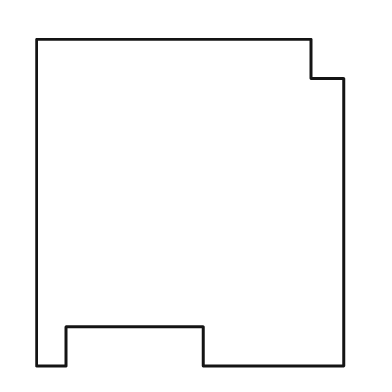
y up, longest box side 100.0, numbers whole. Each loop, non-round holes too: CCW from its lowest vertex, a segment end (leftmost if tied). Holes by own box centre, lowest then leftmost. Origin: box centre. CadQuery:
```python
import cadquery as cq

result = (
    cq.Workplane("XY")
    .moveTo(-47.0, -50.0)
    .lineTo(-38.0, -50.0)
    .lineTo(-38.0, -38.0)
    .lineTo(4.0, -38.0)
    .lineTo(4.0, -50.0)
    .lineTo(47.0, -50.0)
    .lineTo(47.0, 38.0)
    .lineTo(37.0, 38.0)
    .lineTo(37.0, 50.0)
    .lineTo(-47.0, 50.0)
    .close()
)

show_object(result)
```